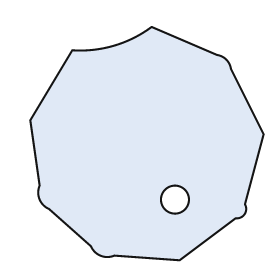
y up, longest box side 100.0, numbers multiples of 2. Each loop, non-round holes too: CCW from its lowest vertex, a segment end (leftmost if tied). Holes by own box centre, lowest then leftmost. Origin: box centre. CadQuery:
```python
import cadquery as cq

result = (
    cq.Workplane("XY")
    .moveTo(14.0, -50.0)
    .lineTo(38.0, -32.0)
    .threePointArc((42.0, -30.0), (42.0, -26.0))
    .lineTo(50.0, 4.0)
    .lineTo(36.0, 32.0)
    .threePointArc((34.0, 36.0), (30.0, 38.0))
    .lineTo(2.0, 50.0)
    .threePointArc((-14.0, 42.0), (-32.0, 40.0))
    .lineTo(-50.0, 10.0)
    .lineTo(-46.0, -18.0)
    .threePointArc((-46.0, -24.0), (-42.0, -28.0))
    .lineTo(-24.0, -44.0)
    .threePointArc((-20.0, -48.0), (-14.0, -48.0))
    .close()
    .moveTo(12.0, -24.0)
    .circle(6.0)
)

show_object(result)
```